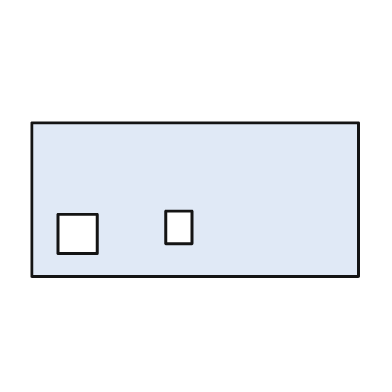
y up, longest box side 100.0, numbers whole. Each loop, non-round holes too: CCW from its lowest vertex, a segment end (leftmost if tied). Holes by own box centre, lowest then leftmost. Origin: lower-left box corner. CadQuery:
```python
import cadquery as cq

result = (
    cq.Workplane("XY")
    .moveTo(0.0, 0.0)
    .lineTo(100.0, 0.0)
    .lineTo(100.0, 47.0)
    .lineTo(0.0, 47.0)
    .close()
    .moveTo(8.0, 7.0)
    .lineTo(20.0, 7.0)
    .lineTo(20.0, 19.0)
    .lineTo(8.0, 19.0)
    .close()
    .moveTo(41.0, 10.0)
    .lineTo(49.0, 10.0)
    .lineTo(49.0, 20.0)
    .lineTo(41.0, 20.0)
    .close()
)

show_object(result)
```